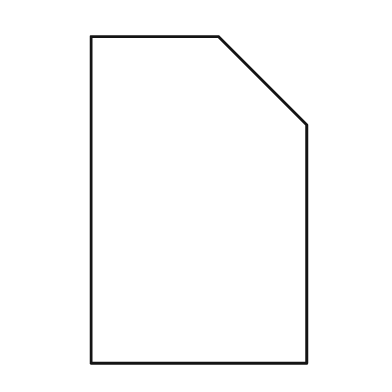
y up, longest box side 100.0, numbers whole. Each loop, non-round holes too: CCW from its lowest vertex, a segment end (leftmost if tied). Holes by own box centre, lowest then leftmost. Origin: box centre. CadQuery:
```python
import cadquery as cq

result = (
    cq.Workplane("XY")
    .moveTo(-33.0, -50.0)
    .lineTo(33.0, -50.0)
    .lineTo(33.0, 23.0)
    .lineTo(6.0, 50.0)
    .lineTo(-33.0, 50.0)
    .close()
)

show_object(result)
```